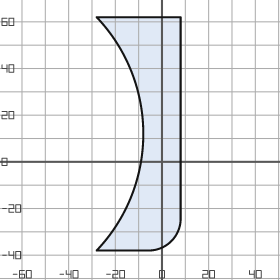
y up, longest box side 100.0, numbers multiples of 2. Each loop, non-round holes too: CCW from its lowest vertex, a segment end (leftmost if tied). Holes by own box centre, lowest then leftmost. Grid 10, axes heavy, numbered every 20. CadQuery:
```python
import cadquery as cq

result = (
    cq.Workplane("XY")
    .moveTo(-28.0, -38.0)
    .lineTo(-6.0, -38.0)
    .threePointArc((4.0, -34.0), (8.0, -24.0))
    .lineTo(8.0, 62.0)
    .lineTo(-28.0, 62.0)
    .threePointArc((-8.0, 12.0), (-28.0, -38.0))
    .close()
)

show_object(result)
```